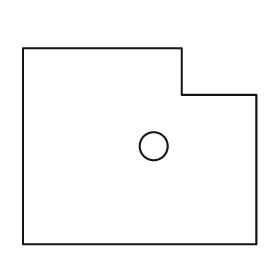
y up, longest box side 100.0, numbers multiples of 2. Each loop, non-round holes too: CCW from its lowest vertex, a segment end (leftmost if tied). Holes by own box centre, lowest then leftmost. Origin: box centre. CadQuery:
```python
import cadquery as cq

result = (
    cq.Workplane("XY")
    .moveTo(-50.0, -42.0)
    .lineTo(50.0, -42.0)
    .lineTo(50.0, 22.0)
    .lineTo(18.0, 22.0)
    .lineTo(18.0, 42.0)
    .lineTo(-50.0, 42.0)
    .close()
    .moveTo(6.0, 0.0)
    .circle(6.0)
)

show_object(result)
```